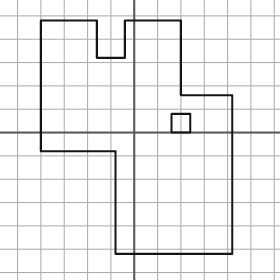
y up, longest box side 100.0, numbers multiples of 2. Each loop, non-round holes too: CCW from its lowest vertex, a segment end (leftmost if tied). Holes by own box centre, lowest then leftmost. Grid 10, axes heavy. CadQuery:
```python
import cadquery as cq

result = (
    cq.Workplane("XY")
    .moveTo(-8.0, -52.0)
    .lineTo(42.0, -52.0)
    .lineTo(42.0, 16.0)
    .lineTo(20.0, 16.0)
    .lineTo(20.0, 48.0)
    .lineTo(-4.0, 48.0)
    .lineTo(-4.0, 32.0)
    .lineTo(-16.0, 32.0)
    .lineTo(-16.0, 48.0)
    .lineTo(-40.0, 48.0)
    .lineTo(-40.0, -8.0)
    .lineTo(-8.0, -8.0)
    .close()
    .moveTo(16.0, 0.0)
    .lineTo(24.0, 0.0)
    .lineTo(24.0, 8.0)
    .lineTo(16.0, 8.0)
    .close()
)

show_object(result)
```